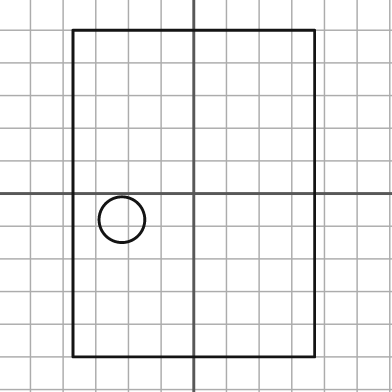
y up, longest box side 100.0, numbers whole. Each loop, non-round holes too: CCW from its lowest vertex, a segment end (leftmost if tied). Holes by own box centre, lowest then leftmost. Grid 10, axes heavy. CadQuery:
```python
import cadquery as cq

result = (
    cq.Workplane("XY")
    .moveTo(-37.0, -50.0)
    .lineTo(37.0, -50.0)
    .lineTo(37.0, 50.0)
    .lineTo(-37.0, 50.0)
    .close()
    .moveTo(-22.0, -8.0)
    .circle(7.0)
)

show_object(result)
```